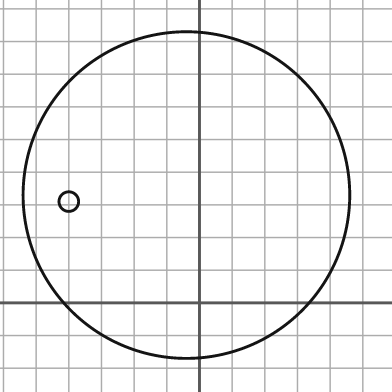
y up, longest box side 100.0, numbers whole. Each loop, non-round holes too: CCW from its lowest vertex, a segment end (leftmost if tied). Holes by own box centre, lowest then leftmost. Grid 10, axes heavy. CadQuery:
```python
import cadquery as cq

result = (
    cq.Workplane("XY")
    .moveTo(-4.0, 33.0)
    .circle(50.0)
    .moveTo(-40.0, 31.0)
    .circle(3.0)
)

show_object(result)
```